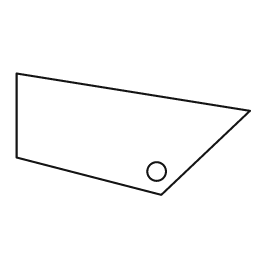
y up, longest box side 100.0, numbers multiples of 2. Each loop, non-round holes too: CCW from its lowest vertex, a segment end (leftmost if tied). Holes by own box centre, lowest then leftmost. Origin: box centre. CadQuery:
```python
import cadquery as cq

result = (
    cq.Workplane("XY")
    .moveTo(12.0, -26.0)
    .lineTo(50.0, 10.0)
    .lineTo(-50.0, 26.0)
    .lineTo(-50.0, -10.0)
    .close()
    .moveTo(10.0, -16.0)
    .circle(4.0)
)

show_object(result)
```